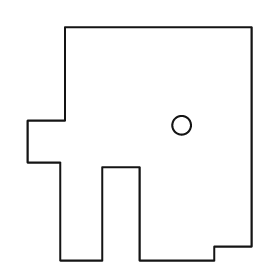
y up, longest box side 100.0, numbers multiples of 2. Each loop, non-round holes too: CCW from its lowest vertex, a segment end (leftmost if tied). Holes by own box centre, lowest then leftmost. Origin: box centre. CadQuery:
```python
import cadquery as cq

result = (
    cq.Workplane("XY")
    .moveTo(-34.0, -50.0)
    .lineTo(-16.0, -50.0)
    .lineTo(-16.0, -10.0)
    .lineTo(0.0, -10.0)
    .lineTo(0.0, -50.0)
    .lineTo(32.0, -50.0)
    .lineTo(32.0, -44.0)
    .lineTo(48.0, -44.0)
    .lineTo(48.0, 50.0)
    .lineTo(-32.0, 50.0)
    .lineTo(-32.0, 10.0)
    .lineTo(-48.0, 10.0)
    .lineTo(-48.0, -8.0)
    .lineTo(-34.0, -8.0)
    .close()
    .moveTo(18.0, 8.0)
    .circle(4.0)
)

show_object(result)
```